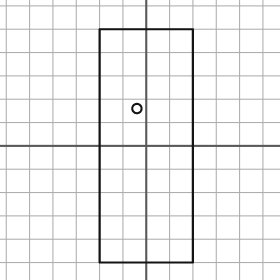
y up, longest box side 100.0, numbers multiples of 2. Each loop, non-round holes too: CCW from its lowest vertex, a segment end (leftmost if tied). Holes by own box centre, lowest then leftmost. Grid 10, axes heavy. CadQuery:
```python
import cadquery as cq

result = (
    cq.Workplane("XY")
    .moveTo(-20.0, -50.0)
    .lineTo(20.0, -50.0)
    .lineTo(20.0, 50.0)
    .lineTo(-20.0, 50.0)
    .close()
    .moveTo(-4.0, 16.0)
    .circle(2.0)
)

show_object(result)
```